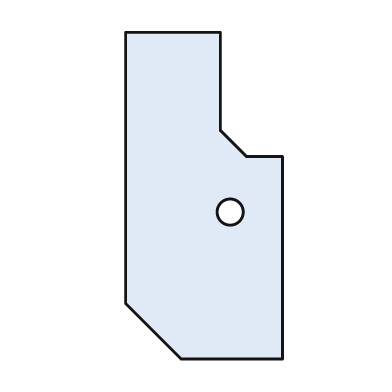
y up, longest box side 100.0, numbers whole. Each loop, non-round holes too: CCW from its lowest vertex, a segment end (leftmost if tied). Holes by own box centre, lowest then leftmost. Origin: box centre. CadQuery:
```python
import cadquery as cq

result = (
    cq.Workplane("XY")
    .moveTo(-7.0, -50.0)
    .lineTo(24.0, -50.0)
    .lineTo(24.0, 12.0)
    .lineTo(13.0, 12.0)
    .lineTo(5.0, 20.0)
    .lineTo(5.0, 50.0)
    .lineTo(-24.0, 50.0)
    .lineTo(-24.0, -33.0)
    .close()
    .moveTo(8.0, -5.0)
    .circle(4.0)
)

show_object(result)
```